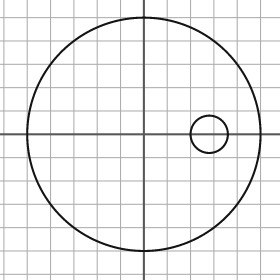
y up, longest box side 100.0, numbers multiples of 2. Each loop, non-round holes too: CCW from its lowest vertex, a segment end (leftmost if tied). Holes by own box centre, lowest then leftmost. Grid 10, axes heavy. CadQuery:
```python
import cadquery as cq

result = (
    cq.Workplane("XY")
    .moveTo(0.0, 0.0)
    .circle(50.0)
    .moveTo(28.0, 0.0)
    .circle(8.0)
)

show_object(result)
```